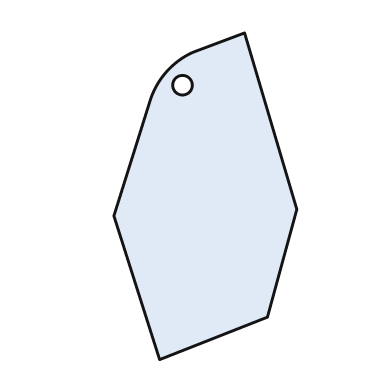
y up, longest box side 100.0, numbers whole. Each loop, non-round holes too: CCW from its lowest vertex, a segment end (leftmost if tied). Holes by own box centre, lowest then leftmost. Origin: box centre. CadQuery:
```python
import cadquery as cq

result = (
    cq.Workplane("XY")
    .moveTo(-14.0, -50.0)
    .lineTo(19.0, -37.0)
    .lineTo(28.0, -4.0)
    .lineTo(12.0, 50.0)
    .lineTo(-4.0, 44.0)
    .threePointArc((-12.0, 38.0), (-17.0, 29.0))
    .lineTo(-28.0, -6.0)
    .close()
    .moveTo(-7.0, 34.0)
    .circle(3.0)
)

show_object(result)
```